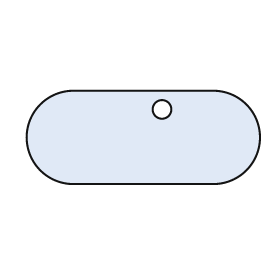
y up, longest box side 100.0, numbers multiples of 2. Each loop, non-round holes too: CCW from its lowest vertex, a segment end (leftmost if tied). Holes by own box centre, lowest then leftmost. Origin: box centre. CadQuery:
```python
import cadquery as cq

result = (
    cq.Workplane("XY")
    .moveTo(-30.0, -20.0)
    .lineTo(30.0, -20.0)
    .threePointArc((50.0, 0.0), (30.0, 20.0))
    .lineTo(-30.0, 20.0)
    .threePointArc((-50.0, 0.0), (-30.0, -20.0))
    .close()
    .moveTo(8.0, 12.0)
    .circle(4.0)
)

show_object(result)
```